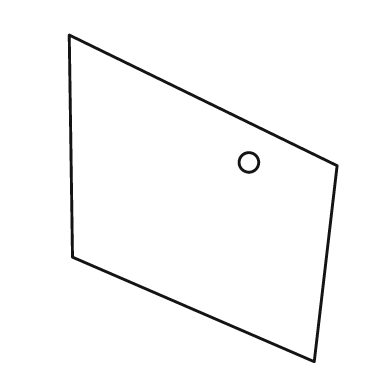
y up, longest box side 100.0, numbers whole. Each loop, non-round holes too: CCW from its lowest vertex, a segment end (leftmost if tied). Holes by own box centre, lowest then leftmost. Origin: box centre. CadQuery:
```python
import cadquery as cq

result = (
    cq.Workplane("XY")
    .moveTo(34.0, -50.0)
    .lineTo(41.0, 10.0)
    .lineTo(-41.0, 50.0)
    .lineTo(-40.0, -18.0)
    .close()
    .moveTo(14.0, 11.0)
    .circle(3.0)
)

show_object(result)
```